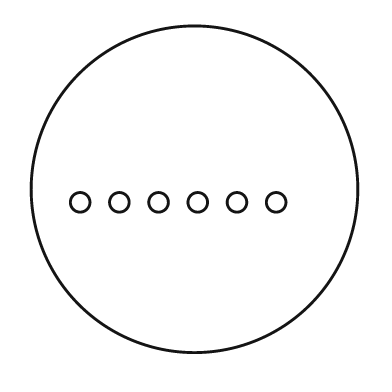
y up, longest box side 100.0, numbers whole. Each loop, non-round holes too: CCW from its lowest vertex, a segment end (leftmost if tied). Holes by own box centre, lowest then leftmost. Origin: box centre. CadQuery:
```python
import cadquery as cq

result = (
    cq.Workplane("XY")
    .moveTo(0.0, 0.0)
    .circle(50.0)
    .moveTo(-35.0, -4.0)
    .circle(3.0)
    .moveTo(-23.0, -4.0)
    .circle(3.0)
    .moveTo(-11.0, -4.0)
    .circle(3.0)
    .moveTo(1.0, -4.0)
    .circle(3.0)
    .moveTo(13.0, -4.0)
    .circle(3.0)
    .moveTo(25.0, -4.0)
    .circle(3.0)
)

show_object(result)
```